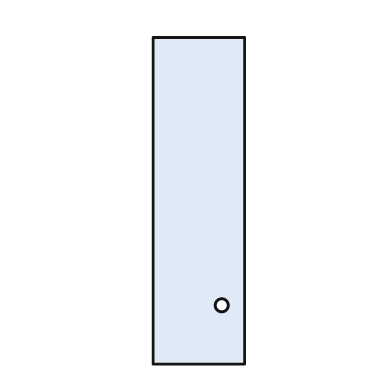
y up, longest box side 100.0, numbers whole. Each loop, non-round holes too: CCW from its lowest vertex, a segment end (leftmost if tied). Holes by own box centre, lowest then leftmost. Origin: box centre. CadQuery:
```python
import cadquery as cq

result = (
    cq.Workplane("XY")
    .moveTo(-14.0, -50.0)
    .lineTo(14.0, -50.0)
    .lineTo(14.0, 50.0)
    .lineTo(-14.0, 50.0)
    .close()
    .moveTo(7.0, -32.0)
    .circle(2.0)
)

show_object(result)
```